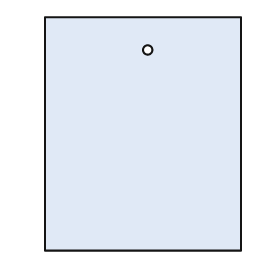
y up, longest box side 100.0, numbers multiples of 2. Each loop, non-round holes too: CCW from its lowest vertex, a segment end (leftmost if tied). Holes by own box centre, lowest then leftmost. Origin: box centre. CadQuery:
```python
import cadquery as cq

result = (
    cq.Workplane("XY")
    .moveTo(-42.0, -50.0)
    .lineTo(42.0, -50.0)
    .lineTo(42.0, 50.0)
    .lineTo(-42.0, 50.0)
    .close()
    .moveTo(2.0, 36.0)
    .circle(2.0)
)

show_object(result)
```